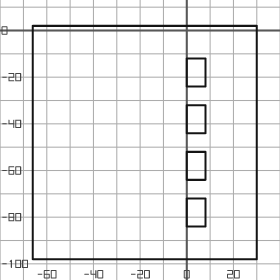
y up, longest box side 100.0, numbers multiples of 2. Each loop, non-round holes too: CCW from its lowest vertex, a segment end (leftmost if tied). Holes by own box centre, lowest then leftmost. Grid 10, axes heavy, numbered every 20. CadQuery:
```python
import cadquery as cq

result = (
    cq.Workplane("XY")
    .moveTo(-66.0, -98.0)
    .lineTo(30.0, -98.0)
    .lineTo(30.0, 2.0)
    .lineTo(-66.0, 2.0)
    .close()
    .moveTo(0.0, -84.0)
    .lineTo(8.0, -84.0)
    .lineTo(8.0, -72.0)
    .lineTo(0.0, -72.0)
    .close()
    .moveTo(0.0, -64.0)
    .lineTo(8.0, -64.0)
    .lineTo(8.0, -52.0)
    .lineTo(0.0, -52.0)
    .close()
    .moveTo(0.0, -44.0)
    .lineTo(8.0, -44.0)
    .lineTo(8.0, -32.0)
    .lineTo(0.0, -32.0)
    .close()
    .moveTo(0.0, -24.0)
    .lineTo(8.0, -24.0)
    .lineTo(8.0, -12.0)
    .lineTo(0.0, -12.0)
    .close()
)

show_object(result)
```